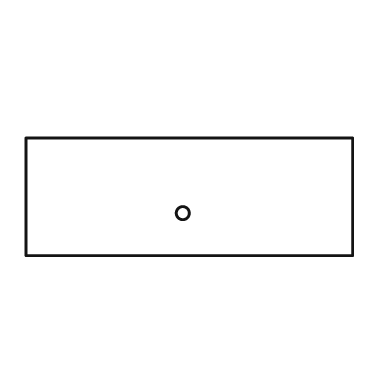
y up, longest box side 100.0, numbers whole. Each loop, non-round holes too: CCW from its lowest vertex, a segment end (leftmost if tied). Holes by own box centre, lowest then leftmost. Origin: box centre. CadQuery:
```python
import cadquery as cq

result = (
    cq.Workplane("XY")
    .moveTo(-50.0, -18.0)
    .lineTo(50.0, -18.0)
    .lineTo(50.0, 18.0)
    .lineTo(-50.0, 18.0)
    .close()
    .moveTo(-2.0, -5.0)
    .circle(2.0)
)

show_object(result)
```